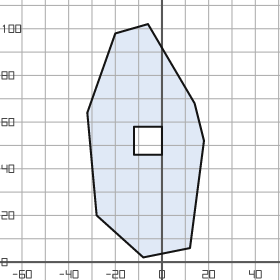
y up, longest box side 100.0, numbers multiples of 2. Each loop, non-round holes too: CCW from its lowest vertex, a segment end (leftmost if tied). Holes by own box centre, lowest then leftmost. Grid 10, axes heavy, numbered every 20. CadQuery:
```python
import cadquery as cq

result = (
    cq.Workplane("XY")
    .moveTo(-8.0, 2.0)
    .lineTo(12.0, 6.0)
    .lineTo(18.0, 52.0)
    .lineTo(14.0, 68.0)
    .lineTo(-6.0, 102.0)
    .lineTo(-20.0, 98.0)
    .lineTo(-32.0, 64.0)
    .lineTo(-28.0, 20.0)
    .close()
    .moveTo(-12.0, 46.0)
    .lineTo(0.0, 46.0)
    .lineTo(0.0, 58.0)
    .lineTo(-12.0, 58.0)
    .close()
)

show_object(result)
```